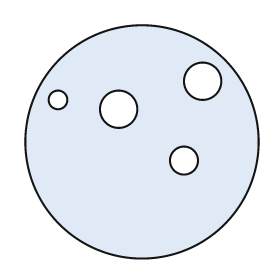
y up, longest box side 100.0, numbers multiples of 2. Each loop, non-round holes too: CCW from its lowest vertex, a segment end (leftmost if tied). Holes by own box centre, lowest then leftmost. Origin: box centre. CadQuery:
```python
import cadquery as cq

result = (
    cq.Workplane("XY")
    .moveTo(0.0, 0.0)
    .circle(50.0)
    .moveTo(18.0, -8.0)
    .circle(6.0)
    .moveTo(-10.0, 14.0)
    .circle(8.0)
    .moveTo(-36.0, 18.0)
    .circle(4.0)
    .moveTo(26.0, 26.0)
    .circle(8.0)
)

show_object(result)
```